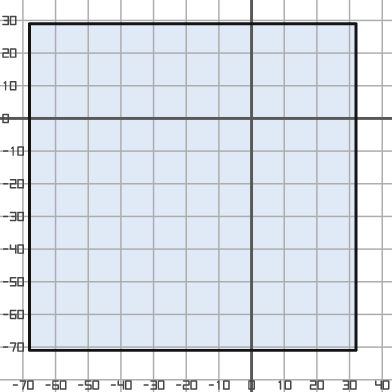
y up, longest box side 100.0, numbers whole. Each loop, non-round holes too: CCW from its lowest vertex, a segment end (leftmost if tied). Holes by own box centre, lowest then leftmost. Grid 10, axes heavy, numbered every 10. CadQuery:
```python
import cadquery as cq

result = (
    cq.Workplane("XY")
    .moveTo(-68.0, -71.0)
    .lineTo(32.0, -71.0)
    .lineTo(32.0, 29.0)
    .lineTo(-68.0, 29.0)
    .close()
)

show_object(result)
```